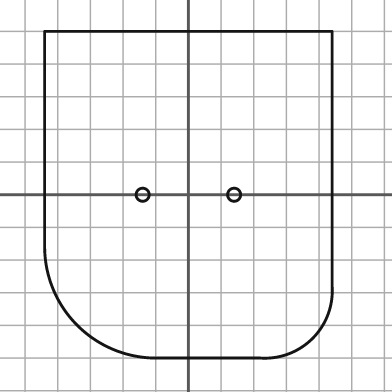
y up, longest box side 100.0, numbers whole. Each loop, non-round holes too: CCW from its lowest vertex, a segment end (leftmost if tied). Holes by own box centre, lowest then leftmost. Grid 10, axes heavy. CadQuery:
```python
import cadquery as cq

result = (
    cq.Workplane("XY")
    .moveTo(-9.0, -50.0)
    .lineTo(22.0, -50.0)
    .threePointArc((38.0, -44.0), (44.0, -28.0))
    .lineTo(44.0, 50.0)
    .lineTo(-44.0, 50.0)
    .lineTo(-44.0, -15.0)
    .threePointArc((-34.0, -40.0), (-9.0, -50.0))
    .close()
    .moveTo(-14.0, 0.0)
    .circle(2.0)
    .moveTo(14.0, 0.0)
    .circle(2.0)
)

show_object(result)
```